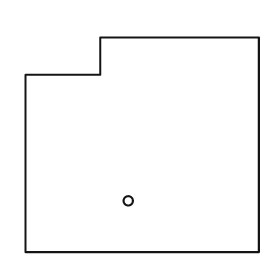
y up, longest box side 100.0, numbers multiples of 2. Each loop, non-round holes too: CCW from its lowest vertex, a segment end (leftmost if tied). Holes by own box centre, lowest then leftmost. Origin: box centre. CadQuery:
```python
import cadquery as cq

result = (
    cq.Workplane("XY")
    .moveTo(-50.0, -46.0)
    .lineTo(50.0, -46.0)
    .lineTo(50.0, 46.0)
    .lineTo(-18.0, 46.0)
    .lineTo(-18.0, 30.0)
    .lineTo(-50.0, 30.0)
    .close()
    .moveTo(-6.0, -24.0)
    .circle(2.0)
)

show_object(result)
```